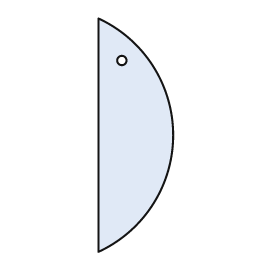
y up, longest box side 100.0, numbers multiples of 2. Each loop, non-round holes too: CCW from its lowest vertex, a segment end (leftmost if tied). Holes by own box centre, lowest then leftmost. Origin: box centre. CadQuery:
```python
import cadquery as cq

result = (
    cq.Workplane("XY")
    .moveTo(-16.0, -50.0)
    .threePointArc((16.0, 0.0), (-16.0, 50.0))
    .close()
    .moveTo(-6.0, 32.0)
    .circle(2.0)
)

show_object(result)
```